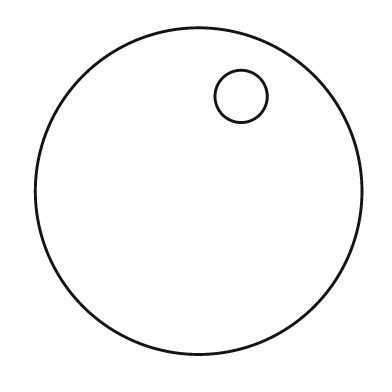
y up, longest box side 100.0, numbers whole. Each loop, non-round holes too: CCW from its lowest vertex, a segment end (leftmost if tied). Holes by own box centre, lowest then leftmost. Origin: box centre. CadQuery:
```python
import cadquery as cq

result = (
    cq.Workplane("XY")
    .moveTo(0.0, 0.0)
    .circle(50.0)
    .moveTo(13.0, 29.0)
    .circle(8.0)
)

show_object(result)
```